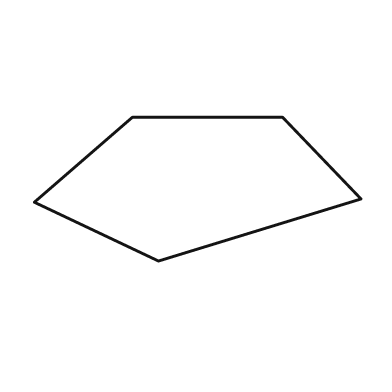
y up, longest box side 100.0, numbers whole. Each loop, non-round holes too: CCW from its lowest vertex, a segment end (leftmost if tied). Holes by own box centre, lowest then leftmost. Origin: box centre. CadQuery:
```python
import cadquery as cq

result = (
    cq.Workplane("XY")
    .moveTo(-12.0, -22.0)
    .lineTo(50.0, -3.0)
    .lineTo(26.0, 22.0)
    .lineTo(-20.0, 22.0)
    .lineTo(-50.0, -4.0)
    .close()
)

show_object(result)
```